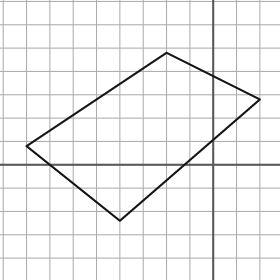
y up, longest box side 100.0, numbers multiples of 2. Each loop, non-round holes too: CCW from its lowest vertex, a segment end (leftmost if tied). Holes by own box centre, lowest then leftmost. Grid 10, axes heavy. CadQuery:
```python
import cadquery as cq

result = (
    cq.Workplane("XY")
    .moveTo(-40.0, -24.0)
    .lineTo(20.0, 28.0)
    .lineTo(-20.0, 48.0)
    .lineTo(-80.0, 8.0)
    .close()
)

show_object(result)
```